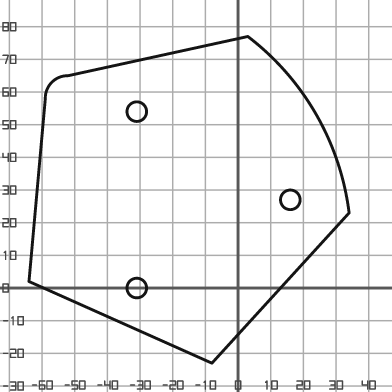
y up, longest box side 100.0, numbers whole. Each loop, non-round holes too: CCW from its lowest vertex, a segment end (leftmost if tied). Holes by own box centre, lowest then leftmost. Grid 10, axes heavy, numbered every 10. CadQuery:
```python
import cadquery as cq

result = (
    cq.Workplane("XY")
    .moveTo(-8.0, -23.0)
    .lineTo(34.0, 23.0)
    .threePointArc((24.0, 53.0), (3.0, 77.0))
    .lineTo(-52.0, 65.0)
    .threePointArc((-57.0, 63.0), (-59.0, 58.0))
    .lineTo(-64.0, 2.0)
    .close()
    .moveTo(-31.0, 0.0)
    .circle(3.0)
    .moveTo(16.0, 27.0)
    .circle(3.0)
    .moveTo(-31.0, 54.0)
    .circle(3.0)
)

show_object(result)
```